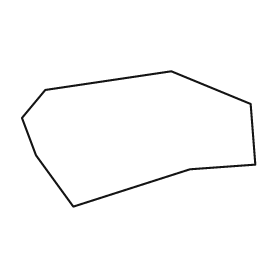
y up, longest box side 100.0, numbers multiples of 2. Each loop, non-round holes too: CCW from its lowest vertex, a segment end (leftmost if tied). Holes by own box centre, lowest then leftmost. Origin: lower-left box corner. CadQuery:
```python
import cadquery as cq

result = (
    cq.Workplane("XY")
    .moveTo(22.0, 0.0)
    .lineTo(72.0, 16.0)
    .lineTo(100.0, 18.0)
    .lineTo(98.0, 44.0)
    .lineTo(64.0, 58.0)
    .lineTo(10.0, 50.0)
    .lineTo(0.0, 38.0)
    .lineTo(6.0, 22.0)
    .close()
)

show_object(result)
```